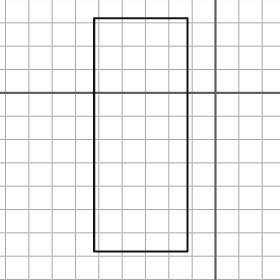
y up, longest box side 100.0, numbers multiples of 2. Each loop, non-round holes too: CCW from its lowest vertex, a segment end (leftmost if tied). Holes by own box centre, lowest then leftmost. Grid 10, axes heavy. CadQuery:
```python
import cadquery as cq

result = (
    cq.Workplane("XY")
    .moveTo(-52.0, -68.0)
    .lineTo(-12.0, -68.0)
    .lineTo(-12.0, 32.0)
    .lineTo(-52.0, 32.0)
    .close()
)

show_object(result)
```